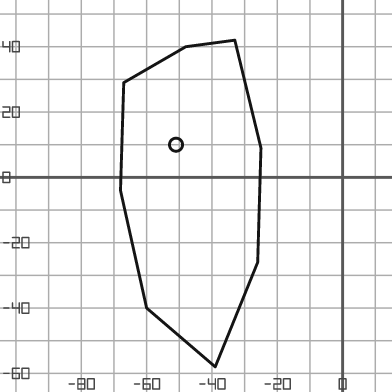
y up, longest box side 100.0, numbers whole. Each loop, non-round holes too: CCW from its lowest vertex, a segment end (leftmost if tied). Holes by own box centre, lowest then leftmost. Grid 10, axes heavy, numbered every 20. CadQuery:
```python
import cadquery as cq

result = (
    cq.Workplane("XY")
    .moveTo(-39.0, -58.0)
    .lineTo(-26.0, -26.0)
    .lineTo(-25.0, 9.0)
    .lineTo(-33.0, 42.0)
    .lineTo(-48.0, 40.0)
    .lineTo(-67.0, 29.0)
    .lineTo(-68.0, -4.0)
    .lineTo(-60.0, -40.0)
    .close()
    .moveTo(-51.0, 10.0)
    .circle(2.0)
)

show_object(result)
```